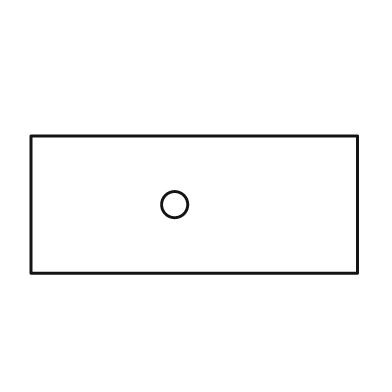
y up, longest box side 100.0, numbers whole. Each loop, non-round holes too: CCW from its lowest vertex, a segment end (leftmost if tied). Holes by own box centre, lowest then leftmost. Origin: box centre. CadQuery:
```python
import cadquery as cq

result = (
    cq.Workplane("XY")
    .moveTo(-50.0, -21.0)
    .lineTo(50.0, -21.0)
    .lineTo(50.0, 21.0)
    .lineTo(-50.0, 21.0)
    .close()
    .moveTo(-6.0, 0.0)
    .circle(4.0)
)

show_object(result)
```